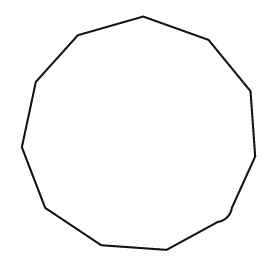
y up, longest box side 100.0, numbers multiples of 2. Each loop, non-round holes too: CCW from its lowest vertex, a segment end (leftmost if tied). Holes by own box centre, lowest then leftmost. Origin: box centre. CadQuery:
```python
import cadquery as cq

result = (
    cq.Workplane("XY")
    .moveTo(12.0, -50.0)
    .lineTo(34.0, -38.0)
    .threePointArc((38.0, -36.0), (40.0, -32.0))
    .lineTo(50.0, -10.0)
    .lineTo(48.0, 18.0)
    .lineTo(30.0, 40.0)
    .lineTo(2.0, 50.0)
    .lineTo(-26.0, 42.0)
    .lineTo(-44.0, 22.0)
    .lineTo(-50.0, -6.0)
    .lineTo(-40.0, -32.0)
    .lineTo(-16.0, -48.0)
    .close()
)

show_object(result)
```